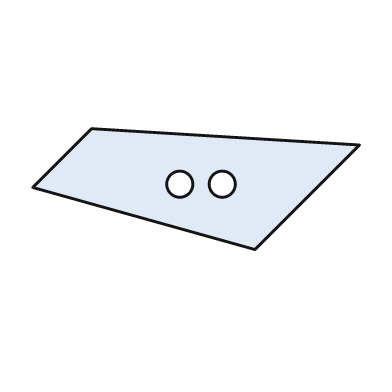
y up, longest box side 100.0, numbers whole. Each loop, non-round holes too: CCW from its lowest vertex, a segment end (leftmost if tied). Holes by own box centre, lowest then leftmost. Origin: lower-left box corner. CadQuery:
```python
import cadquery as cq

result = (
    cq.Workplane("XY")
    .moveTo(68.0, 0.0)
    .lineTo(100.0, 32.0)
    .lineTo(18.0, 37.0)
    .lineTo(0.0, 19.0)
    .close()
    .moveTo(45.0, 20.0)
    .circle(4.0)
    .moveTo(58.0, 20.0)
    .circle(4.0)
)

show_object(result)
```